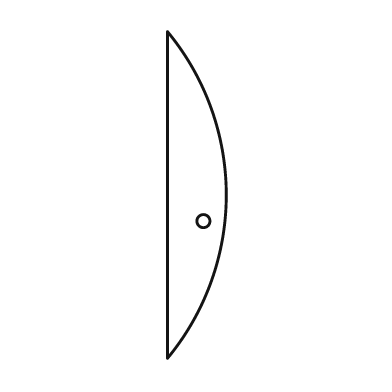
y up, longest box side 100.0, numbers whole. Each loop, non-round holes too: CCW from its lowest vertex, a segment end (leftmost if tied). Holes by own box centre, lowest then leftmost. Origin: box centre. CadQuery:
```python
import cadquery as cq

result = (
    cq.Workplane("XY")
    .moveTo(-9.0, -50.0)
    .threePointArc((9.0, 0.0), (-9.0, 50.0))
    .close()
    .moveTo(2.0, -8.0)
    .circle(2.0)
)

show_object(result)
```